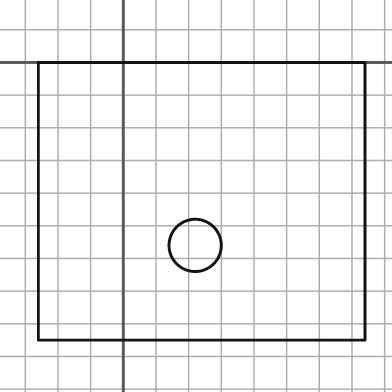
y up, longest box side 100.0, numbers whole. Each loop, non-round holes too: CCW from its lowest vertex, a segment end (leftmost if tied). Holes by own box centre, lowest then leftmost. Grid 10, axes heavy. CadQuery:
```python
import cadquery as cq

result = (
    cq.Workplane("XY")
    .moveTo(-26.0, -85.0)
    .lineTo(74.0, -85.0)
    .lineTo(74.0, 0.0)
    .lineTo(-26.0, 0.0)
    .close()
    .moveTo(22.0, -56.0)
    .circle(8.0)
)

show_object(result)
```